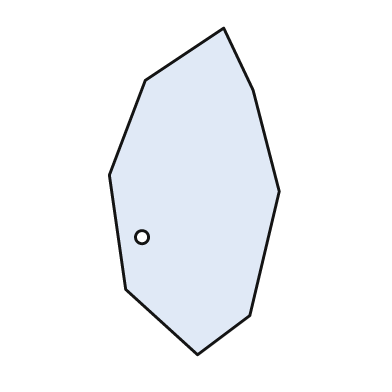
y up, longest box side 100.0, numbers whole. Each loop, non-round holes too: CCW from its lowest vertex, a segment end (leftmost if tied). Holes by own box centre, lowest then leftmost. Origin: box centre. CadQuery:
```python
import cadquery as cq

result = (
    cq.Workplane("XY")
    .moveTo(1.0, -50.0)
    .lineTo(17.0, -38.0)
    .lineTo(26.0, 0.0)
    .lineTo(18.0, 31.0)
    .lineTo(9.0, 50.0)
    .lineTo(-15.0, 34.0)
    .lineTo(-26.0, 5.0)
    .lineTo(-21.0, -30.0)
    .close()
    .moveTo(-16.0, -14.0)
    .circle(2.0)
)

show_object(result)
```